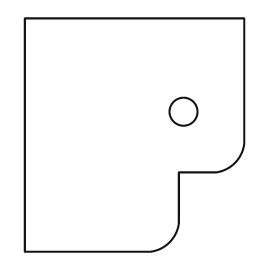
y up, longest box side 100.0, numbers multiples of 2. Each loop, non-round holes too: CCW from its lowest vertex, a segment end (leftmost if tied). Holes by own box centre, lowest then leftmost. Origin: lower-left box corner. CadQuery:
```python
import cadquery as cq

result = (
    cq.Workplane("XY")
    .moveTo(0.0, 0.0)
    .lineTo(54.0, 0.0)
    .threePointArc((62.0, 4.0), (66.0, 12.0))
    .lineTo(66.0, 34.0)
    .lineTo(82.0, 34.0)
    .threePointArc((90.0, 38.0), (94.0, 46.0))
    .lineTo(94.0, 100.0)
    .lineTo(0.0, 100.0)
    .close()
    .moveTo(68.0, 60.0)
    .circle(6.0)
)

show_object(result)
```